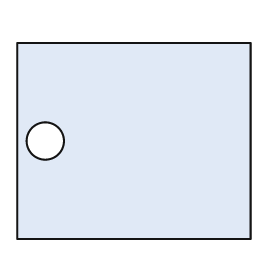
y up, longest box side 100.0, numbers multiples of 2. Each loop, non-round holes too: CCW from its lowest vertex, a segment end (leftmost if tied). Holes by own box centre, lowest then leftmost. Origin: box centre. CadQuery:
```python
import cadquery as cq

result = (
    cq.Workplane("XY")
    .moveTo(-50.0, -42.0)
    .lineTo(50.0, -42.0)
    .lineTo(50.0, 42.0)
    .lineTo(-50.0, 42.0)
    .close()
    .moveTo(-38.0, 0.0)
    .circle(8.0)
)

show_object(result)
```